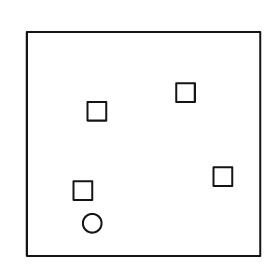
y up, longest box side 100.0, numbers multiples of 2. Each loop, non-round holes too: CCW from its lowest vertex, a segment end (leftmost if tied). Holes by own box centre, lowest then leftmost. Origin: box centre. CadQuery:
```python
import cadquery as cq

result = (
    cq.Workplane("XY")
    .moveTo(-50.0, -48.0)
    .lineTo(50.0, -48.0)
    .lineTo(50.0, 48.0)
    .lineTo(-50.0, 48.0)
    .close()
    .moveTo(-22.0, -34.0)
    .circle(4.0)
    .moveTo(-30.0, -24.0)
    .lineTo(-22.0, -24.0)
    .lineTo(-22.0, -16.0)
    .lineTo(-30.0, -16.0)
    .close()
    .moveTo(30.0, -18.0)
    .lineTo(38.0, -18.0)
    .lineTo(38.0, -10.0)
    .lineTo(30.0, -10.0)
    .close()
    .moveTo(-24.0, 10.0)
    .lineTo(-16.0, 10.0)
    .lineTo(-16.0, 18.0)
    .lineTo(-24.0, 18.0)
    .close()
    .moveTo(14.0, 18.0)
    .lineTo(22.0, 18.0)
    .lineTo(22.0, 26.0)
    .lineTo(14.0, 26.0)
    .close()
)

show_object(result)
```